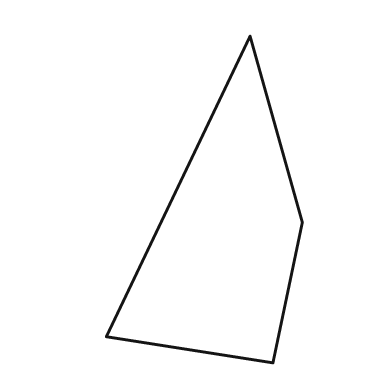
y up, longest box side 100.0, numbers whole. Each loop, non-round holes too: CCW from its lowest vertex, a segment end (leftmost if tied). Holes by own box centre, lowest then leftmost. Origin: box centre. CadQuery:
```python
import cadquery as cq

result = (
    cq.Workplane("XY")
    .moveTo(21.0, -50.0)
    .lineTo(30.0, -7.0)
    .lineTo(14.0, 50.0)
    .lineTo(-30.0, -42.0)
    .close()
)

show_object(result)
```